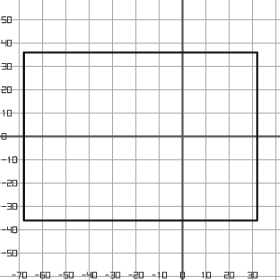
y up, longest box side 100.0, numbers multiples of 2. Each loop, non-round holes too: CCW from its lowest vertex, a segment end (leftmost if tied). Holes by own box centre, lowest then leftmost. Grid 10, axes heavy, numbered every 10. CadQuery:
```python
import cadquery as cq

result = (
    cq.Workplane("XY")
    .moveTo(-68.0, -36.0)
    .lineTo(32.0, -36.0)
    .lineTo(32.0, 36.0)
    .lineTo(-68.0, 36.0)
    .close()
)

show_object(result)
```